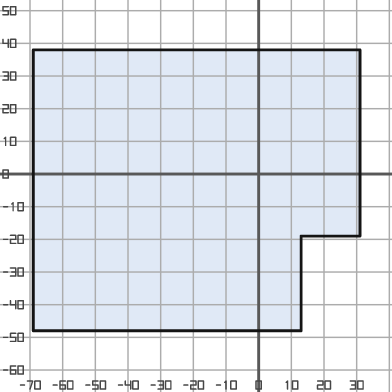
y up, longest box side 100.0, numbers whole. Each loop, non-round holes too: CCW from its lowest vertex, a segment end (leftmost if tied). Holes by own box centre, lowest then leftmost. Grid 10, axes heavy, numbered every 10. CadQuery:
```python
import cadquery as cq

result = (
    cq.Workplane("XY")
    .moveTo(-69.0, -48.0)
    .lineTo(13.0, -48.0)
    .lineTo(13.0, -19.0)
    .lineTo(31.0, -19.0)
    .lineTo(31.0, 38.0)
    .lineTo(-69.0, 38.0)
    .close()
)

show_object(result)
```